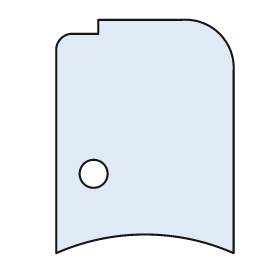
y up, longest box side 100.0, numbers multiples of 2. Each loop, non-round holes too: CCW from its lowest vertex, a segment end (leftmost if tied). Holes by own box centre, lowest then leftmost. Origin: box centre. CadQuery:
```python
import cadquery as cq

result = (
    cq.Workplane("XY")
    .moveTo(-38.0, -50.0)
    .threePointArc((0.0, -42.0), (38.0, -50.0))
    .lineTo(38.0, 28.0)
    .threePointArc((32.0, 44.0), (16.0, 50.0))
    .lineTo(-20.0, 50.0)
    .lineTo(-20.0, 44.0)
    .lineTo(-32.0, 44.0)
    .threePointArc((-36.0, 42.0), (-38.0, 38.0))
    .close()
    .moveTo(-22.0, -16.0)
    .circle(6.0)
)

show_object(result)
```